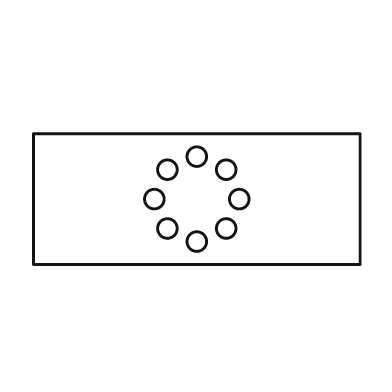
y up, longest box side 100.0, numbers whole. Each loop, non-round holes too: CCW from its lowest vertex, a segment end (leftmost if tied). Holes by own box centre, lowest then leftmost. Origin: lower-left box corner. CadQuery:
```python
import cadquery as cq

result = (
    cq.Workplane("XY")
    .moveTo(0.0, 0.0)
    .lineTo(100.0, 0.0)
    .lineTo(100.0, 40.0)
    .lineTo(0.0, 40.0)
    .close()
    .moveTo(50.0, 7.0)
    .circle(3.0)
    .moveTo(41.0, 11.0)
    .circle(3.0)
    .moveTo(59.0, 11.0)
    .circle(3.0)
    .moveTo(37.0, 20.0)
    .circle(3.0)
    .moveTo(63.0, 20.0)
    .circle(3.0)
    .moveTo(41.0, 29.0)
    .circle(3.0)
    .moveTo(59.0, 29.0)
    .circle(3.0)
    .moveTo(50.0, 33.0)
    .circle(3.0)
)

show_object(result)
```